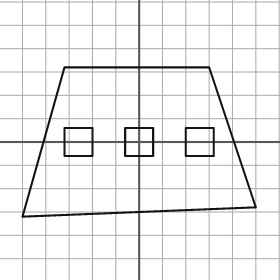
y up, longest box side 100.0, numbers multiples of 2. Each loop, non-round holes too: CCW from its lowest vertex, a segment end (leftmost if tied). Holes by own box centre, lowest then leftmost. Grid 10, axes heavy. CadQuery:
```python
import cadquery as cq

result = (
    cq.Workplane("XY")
    .moveTo(-50.0, -32.0)
    .lineTo(50.0, -28.0)
    .lineTo(30.0, 32.0)
    .lineTo(-32.0, 32.0)
    .close()
    .moveTo(-32.0, -6.0)
    .lineTo(-20.0, -6.0)
    .lineTo(-20.0, 6.0)
    .lineTo(-32.0, 6.0)
    .close()
    .moveTo(-6.0, -6.0)
    .lineTo(6.0, -6.0)
    .lineTo(6.0, 6.0)
    .lineTo(-6.0, 6.0)
    .close()
    .moveTo(20.0, -6.0)
    .lineTo(32.0, -6.0)
    .lineTo(32.0, 6.0)
    .lineTo(20.0, 6.0)
    .close()
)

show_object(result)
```